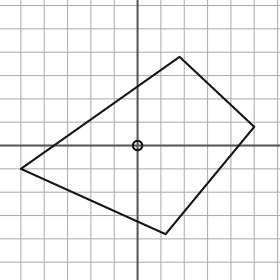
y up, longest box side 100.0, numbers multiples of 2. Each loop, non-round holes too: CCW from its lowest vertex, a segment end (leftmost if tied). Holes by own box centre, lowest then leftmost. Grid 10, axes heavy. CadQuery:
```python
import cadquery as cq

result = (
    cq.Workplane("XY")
    .moveTo(12.0, -38.0)
    .lineTo(50.0, 8.0)
    .lineTo(18.0, 38.0)
    .lineTo(-50.0, -10.0)
    .close()
    .moveTo(0.0, 0.0)
    .circle(2.0)
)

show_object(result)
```